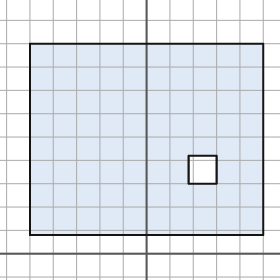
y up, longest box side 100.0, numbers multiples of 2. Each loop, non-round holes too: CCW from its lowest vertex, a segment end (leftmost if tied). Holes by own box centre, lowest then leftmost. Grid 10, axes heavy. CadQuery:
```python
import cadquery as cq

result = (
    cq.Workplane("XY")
    .moveTo(-50.0, 8.0)
    .lineTo(50.0, 8.0)
    .lineTo(50.0, 90.0)
    .lineTo(-50.0, 90.0)
    .close()
    .moveTo(18.0, 30.0)
    .lineTo(30.0, 30.0)
    .lineTo(30.0, 42.0)
    .lineTo(18.0, 42.0)
    .close()
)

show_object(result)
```